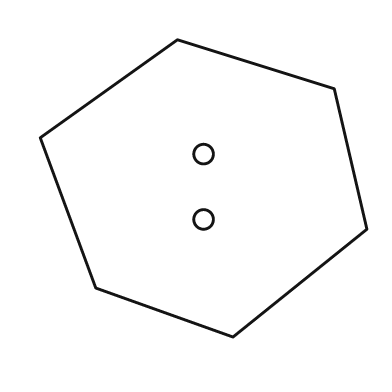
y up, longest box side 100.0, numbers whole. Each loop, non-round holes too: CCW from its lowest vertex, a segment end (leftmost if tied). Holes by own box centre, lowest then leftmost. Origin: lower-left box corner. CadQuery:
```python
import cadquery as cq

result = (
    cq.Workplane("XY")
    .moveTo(59.0, 0.0)
    .lineTo(100.0, 33.0)
    .lineTo(90.0, 76.0)
    .lineTo(42.0, 91.0)
    .lineTo(0.0, 61.0)
    .lineTo(17.0, 15.0)
    .close()
    .moveTo(50.0, 36.0)
    .circle(3.0)
    .moveTo(50.0, 56.0)
    .circle(3.0)
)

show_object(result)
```